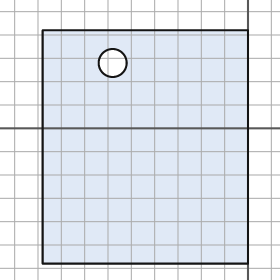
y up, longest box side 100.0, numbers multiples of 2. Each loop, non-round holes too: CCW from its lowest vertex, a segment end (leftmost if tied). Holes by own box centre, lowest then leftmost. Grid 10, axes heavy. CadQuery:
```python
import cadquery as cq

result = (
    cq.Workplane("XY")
    .moveTo(-88.0, -58.0)
    .lineTo(0.0, -58.0)
    .lineTo(0.0, 42.0)
    .lineTo(-88.0, 42.0)
    .close()
    .moveTo(-58.0, 28.0)
    .circle(6.0)
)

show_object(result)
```